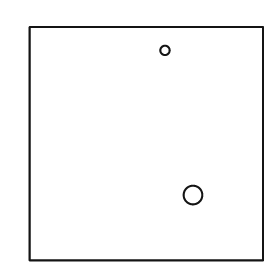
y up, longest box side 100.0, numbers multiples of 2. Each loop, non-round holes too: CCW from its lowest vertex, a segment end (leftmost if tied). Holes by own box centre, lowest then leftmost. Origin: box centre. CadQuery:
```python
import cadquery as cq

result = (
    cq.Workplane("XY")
    .moveTo(-50.0, -50.0)
    .lineTo(50.0, -50.0)
    .lineTo(50.0, 50.0)
    .lineTo(-50.0, 50.0)
    .close()
    .moveTo(20.0, -22.0)
    .circle(4.0)
    .moveTo(8.0, 40.0)
    .circle(2.0)
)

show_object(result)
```